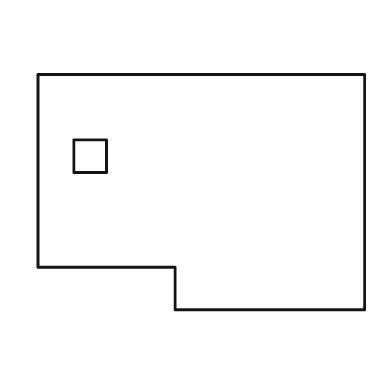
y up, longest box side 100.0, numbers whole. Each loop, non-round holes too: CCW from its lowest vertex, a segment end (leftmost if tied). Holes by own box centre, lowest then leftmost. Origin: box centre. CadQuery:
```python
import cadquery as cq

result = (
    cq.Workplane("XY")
    .moveTo(-8.0, -36.0)
    .lineTo(50.0, -36.0)
    .lineTo(50.0, 36.0)
    .lineTo(-50.0, 36.0)
    .lineTo(-50.0, -23.0)
    .lineTo(-8.0, -23.0)
    .close()
    .moveTo(-39.0, 6.0)
    .lineTo(-29.0, 6.0)
    .lineTo(-29.0, 16.0)
    .lineTo(-39.0, 16.0)
    .close()
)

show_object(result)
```